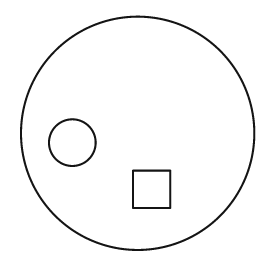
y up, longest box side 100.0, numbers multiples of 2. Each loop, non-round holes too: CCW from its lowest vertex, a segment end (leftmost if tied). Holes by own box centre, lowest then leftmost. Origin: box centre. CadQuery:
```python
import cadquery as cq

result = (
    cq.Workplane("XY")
    .moveTo(0.0, 0.0)
    .circle(50.0)
    .moveTo(-2.0, -32.0)
    .lineTo(14.0, -32.0)
    .lineTo(14.0, -16.0)
    .lineTo(-2.0, -16.0)
    .close()
    .moveTo(-28.0, -4.0)
    .circle(10.0)
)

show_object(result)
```